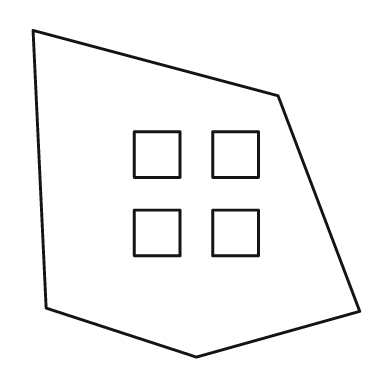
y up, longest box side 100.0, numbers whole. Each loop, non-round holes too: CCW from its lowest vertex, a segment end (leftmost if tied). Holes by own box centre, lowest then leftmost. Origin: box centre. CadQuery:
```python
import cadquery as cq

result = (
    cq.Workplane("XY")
    .moveTo(0.0, -50.0)
    .lineTo(50.0, -36.0)
    .lineTo(25.0, 30.0)
    .lineTo(-50.0, 50.0)
    .lineTo(-46.0, -35.0)
    .close()
    .moveTo(-19.0, -19.0)
    .lineTo(-5.0, -19.0)
    .lineTo(-5.0, -5.0)
    .lineTo(-19.0, -5.0)
    .close()
    .moveTo(5.0, -19.0)
    .lineTo(19.0, -19.0)
    .lineTo(19.0, -5.0)
    .lineTo(5.0, -5.0)
    .close()
    .moveTo(-19.0, 5.0)
    .lineTo(-5.0, 5.0)
    .lineTo(-5.0, 19.0)
    .lineTo(-19.0, 19.0)
    .close()
    .moveTo(5.0, 5.0)
    .lineTo(19.0, 5.0)
    .lineTo(19.0, 19.0)
    .lineTo(5.0, 19.0)
    .close()
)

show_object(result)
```